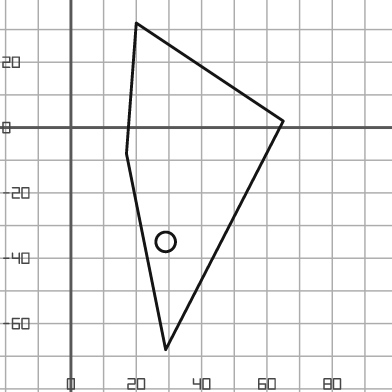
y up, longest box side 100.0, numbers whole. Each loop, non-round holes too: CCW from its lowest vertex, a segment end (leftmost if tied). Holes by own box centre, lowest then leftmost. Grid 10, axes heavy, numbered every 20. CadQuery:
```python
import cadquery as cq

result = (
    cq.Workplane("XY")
    .moveTo(29.0, -68.0)
    .lineTo(65.0, 2.0)
    .lineTo(20.0, 32.0)
    .lineTo(17.0, -8.0)
    .close()
    .moveTo(29.0, -35.0)
    .circle(3.0)
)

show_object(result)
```